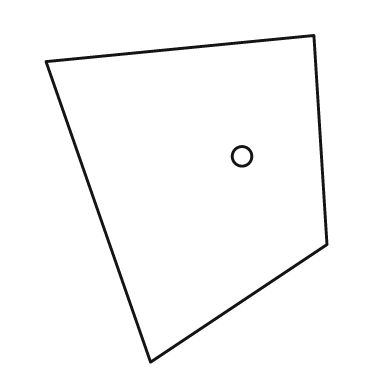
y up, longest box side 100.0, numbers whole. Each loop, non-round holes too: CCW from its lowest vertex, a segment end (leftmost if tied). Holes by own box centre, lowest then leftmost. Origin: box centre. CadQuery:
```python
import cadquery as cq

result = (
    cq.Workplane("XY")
    .moveTo(-11.0, -50.0)
    .lineTo(43.0, -14.0)
    .lineTo(39.0, 50.0)
    .lineTo(-43.0, 42.0)
    .close()
    .moveTo(17.0, 13.0)
    .circle(3.0)
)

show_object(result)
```